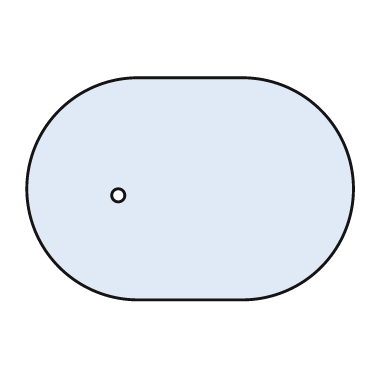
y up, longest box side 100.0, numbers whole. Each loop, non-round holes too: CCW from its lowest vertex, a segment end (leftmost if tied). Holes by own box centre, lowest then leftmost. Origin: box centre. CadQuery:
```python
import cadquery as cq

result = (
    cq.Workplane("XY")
    .moveTo(-16.0, -34.0)
    .lineTo(16.0, -34.0)
    .threePointArc((50.0, 0.0), (16.0, 34.0))
    .lineTo(-16.0, 34.0)
    .threePointArc((-50.0, 0.0), (-16.0, -34.0))
    .close()
    .moveTo(-22.0, -2.0)
    .circle(2.0)
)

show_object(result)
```